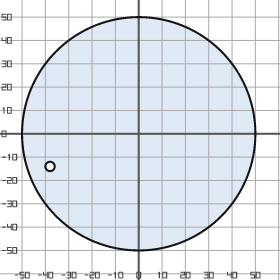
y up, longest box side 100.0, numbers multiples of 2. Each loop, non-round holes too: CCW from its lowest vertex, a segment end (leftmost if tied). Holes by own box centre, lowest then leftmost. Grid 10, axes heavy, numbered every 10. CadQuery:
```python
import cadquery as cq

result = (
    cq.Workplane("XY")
    .moveTo(0.0, 0.0)
    .circle(50.0)
    .moveTo(-38.0, -14.0)
    .circle(2.0)
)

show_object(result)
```